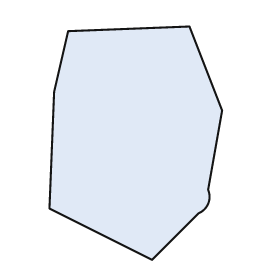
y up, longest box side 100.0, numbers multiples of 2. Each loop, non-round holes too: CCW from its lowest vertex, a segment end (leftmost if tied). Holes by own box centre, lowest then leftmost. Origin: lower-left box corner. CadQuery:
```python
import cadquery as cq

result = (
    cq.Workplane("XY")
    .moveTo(44.0, 0.0)
    .lineTo(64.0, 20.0)
    .threePointArc((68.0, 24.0), (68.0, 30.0))
    .lineTo(74.0, 64.0)
    .lineTo(60.0, 100.0)
    .lineTo(8.0, 98.0)
    .lineTo(2.0, 72.0)
    .lineTo(0.0, 22.0)
    .close()
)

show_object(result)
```